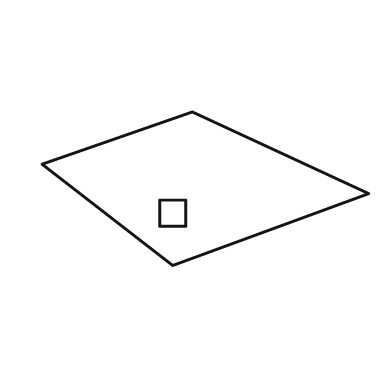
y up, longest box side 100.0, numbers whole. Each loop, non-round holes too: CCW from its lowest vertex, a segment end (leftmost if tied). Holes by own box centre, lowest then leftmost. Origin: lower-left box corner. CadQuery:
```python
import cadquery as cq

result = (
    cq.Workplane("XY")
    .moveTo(40.0, 0.0)
    .lineTo(100.0, 22.0)
    .lineTo(46.0, 47.0)
    .lineTo(0.0, 31.0)
    .close()
    .moveTo(36.0, 12.0)
    .lineTo(44.0, 12.0)
    .lineTo(44.0, 20.0)
    .lineTo(36.0, 20.0)
    .close()
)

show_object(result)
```